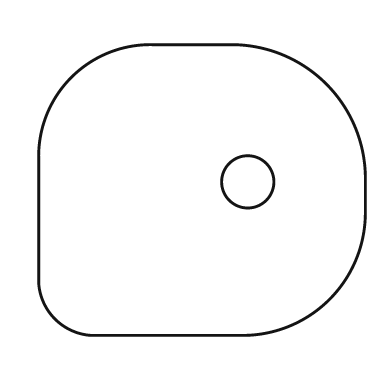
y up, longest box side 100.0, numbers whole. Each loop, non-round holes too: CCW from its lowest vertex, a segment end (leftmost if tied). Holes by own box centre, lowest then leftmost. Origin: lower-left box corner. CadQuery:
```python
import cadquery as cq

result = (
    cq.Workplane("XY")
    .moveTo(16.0, 0.0)
    .lineTo(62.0, 0.0)
    .threePointArc((89.0, 11.0), (100.0, 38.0))
    .lineTo(100.0, 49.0)
    .threePointArc((88.0, 77.0), (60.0, 89.0))
    .lineTo(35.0, 89.0)
    .threePointArc((10.0, 79.0), (0.0, 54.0))
    .lineTo(0.0, 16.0)
    .threePointArc((5.0, 5.0), (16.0, 0.0))
    .close()
    .moveTo(64.0, 47.0)
    .circle(8.0)
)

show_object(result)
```